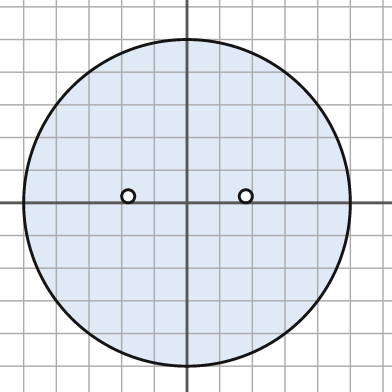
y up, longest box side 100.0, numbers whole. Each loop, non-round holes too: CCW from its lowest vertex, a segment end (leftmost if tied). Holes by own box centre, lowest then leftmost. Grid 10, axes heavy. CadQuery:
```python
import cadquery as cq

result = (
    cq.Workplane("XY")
    .moveTo(0.0, 0.0)
    .circle(50.0)
    .moveTo(-18.0, 2.0)
    .circle(2.0)
    .moveTo(18.0, 2.0)
    .circle(2.0)
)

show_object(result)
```